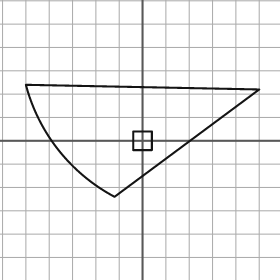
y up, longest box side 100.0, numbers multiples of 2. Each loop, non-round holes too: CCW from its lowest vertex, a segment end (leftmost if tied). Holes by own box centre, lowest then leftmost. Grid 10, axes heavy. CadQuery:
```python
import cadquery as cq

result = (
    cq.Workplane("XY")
    .moveTo(-12.0, -24.0)
    .lineTo(50.0, 22.0)
    .lineTo(-50.0, 24.0)
    .threePointArc((-36.0, -4.0), (-12.0, -24.0))
    .close()
    .moveTo(-4.0, -4.0)
    .lineTo(4.0, -4.0)
    .lineTo(4.0, 4.0)
    .lineTo(-4.0, 4.0)
    .close()
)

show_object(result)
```